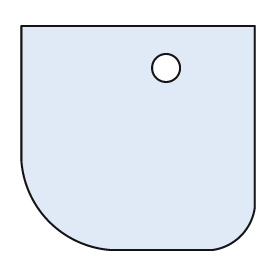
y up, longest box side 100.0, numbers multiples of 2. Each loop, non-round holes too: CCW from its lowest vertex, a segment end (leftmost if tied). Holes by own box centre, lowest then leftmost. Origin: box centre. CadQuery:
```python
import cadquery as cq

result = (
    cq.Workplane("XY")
    .moveTo(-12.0, -48.0)
    .lineTo(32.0, -48.0)
    .threePointArc((44.0, -42.0), (50.0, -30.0))
    .lineTo(50.0, 48.0)
    .lineTo(-50.0, 48.0)
    .lineTo(-50.0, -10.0)
    .threePointArc((-38.0, -36.0), (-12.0, -48.0))
    .close()
    .moveTo(12.0, 30.0)
    .circle(6.0)
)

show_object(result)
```